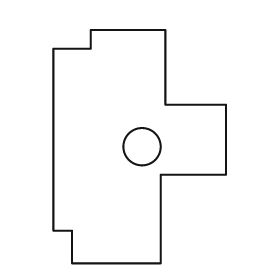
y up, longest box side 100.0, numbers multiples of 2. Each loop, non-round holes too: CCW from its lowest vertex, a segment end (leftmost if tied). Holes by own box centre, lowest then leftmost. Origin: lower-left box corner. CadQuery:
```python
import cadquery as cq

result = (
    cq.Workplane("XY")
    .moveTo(8.0, 0.0)
    .lineTo(46.0, 0.0)
    .lineTo(46.0, 38.0)
    .lineTo(74.0, 38.0)
    .lineTo(74.0, 68.0)
    .lineTo(48.0, 68.0)
    .lineTo(48.0, 100.0)
    .lineTo(16.0, 100.0)
    .lineTo(16.0, 92.0)
    .lineTo(0.0, 92.0)
    .lineTo(0.0, 14.0)
    .lineTo(8.0, 14.0)
    .close()
    .moveTo(38.0, 50.0)
    .circle(8.0)
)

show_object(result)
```